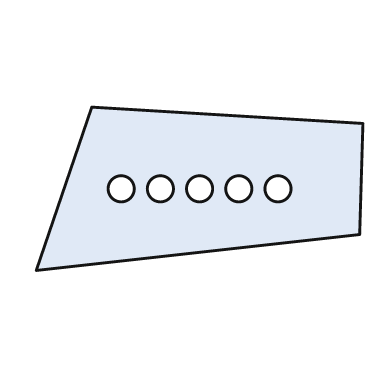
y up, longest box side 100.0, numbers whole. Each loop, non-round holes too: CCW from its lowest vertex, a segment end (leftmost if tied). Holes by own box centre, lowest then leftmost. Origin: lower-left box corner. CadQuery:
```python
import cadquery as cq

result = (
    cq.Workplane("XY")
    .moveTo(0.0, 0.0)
    .lineTo(99.0, 11.0)
    .lineTo(100.0, 45.0)
    .lineTo(17.0, 50.0)
    .close()
    .moveTo(26.0, 25.0)
    .circle(4.0)
    .moveTo(38.0, 25.0)
    .circle(4.0)
    .moveTo(50.0, 25.0)
    .circle(4.0)
    .moveTo(62.0, 25.0)
    .circle(4.0)
    .moveTo(74.0, 25.0)
    .circle(4.0)
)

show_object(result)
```